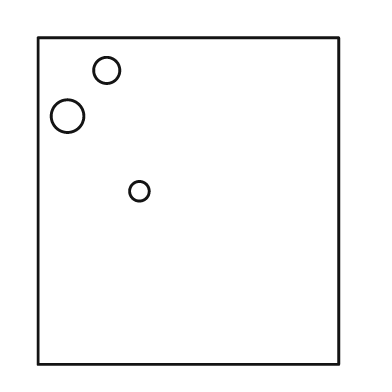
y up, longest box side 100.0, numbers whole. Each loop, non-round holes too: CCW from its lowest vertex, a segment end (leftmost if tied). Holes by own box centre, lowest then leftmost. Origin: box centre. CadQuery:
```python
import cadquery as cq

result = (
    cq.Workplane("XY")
    .moveTo(-46.0, -50.0)
    .lineTo(46.0, -50.0)
    .lineTo(46.0, 50.0)
    .lineTo(-46.0, 50.0)
    .close()
    .moveTo(-15.0, 3.0)
    .circle(3.0)
    .moveTo(-37.0, 26.0)
    .circle(5.0)
    .moveTo(-25.0, 40.0)
    .circle(4.0)
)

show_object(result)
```